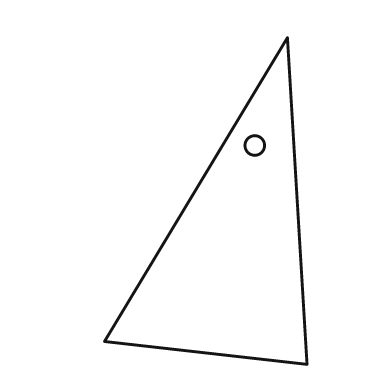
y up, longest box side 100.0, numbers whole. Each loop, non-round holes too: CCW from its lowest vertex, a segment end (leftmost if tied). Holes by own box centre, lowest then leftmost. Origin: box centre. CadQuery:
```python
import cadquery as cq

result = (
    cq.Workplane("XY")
    .moveTo(31.0, -50.0)
    .lineTo(25.0, 50.0)
    .lineTo(-31.0, -43.0)
    .close()
    .moveTo(15.0, 17.0)
    .circle(3.0)
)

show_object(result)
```